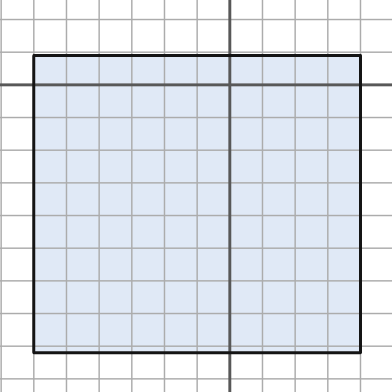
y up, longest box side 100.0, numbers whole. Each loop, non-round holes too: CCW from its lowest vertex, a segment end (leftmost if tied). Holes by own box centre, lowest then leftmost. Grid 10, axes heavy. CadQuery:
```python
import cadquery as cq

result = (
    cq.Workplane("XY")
    .moveTo(-60.0, -82.0)
    .lineTo(40.0, -82.0)
    .lineTo(40.0, 9.0)
    .lineTo(-60.0, 9.0)
    .close()
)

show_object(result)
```